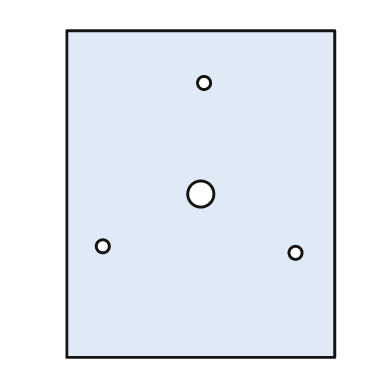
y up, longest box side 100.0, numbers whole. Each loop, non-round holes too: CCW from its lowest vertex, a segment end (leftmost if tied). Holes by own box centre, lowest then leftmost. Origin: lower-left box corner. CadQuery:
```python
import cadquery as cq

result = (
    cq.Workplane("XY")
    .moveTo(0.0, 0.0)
    .lineTo(82.0, 0.0)
    .lineTo(82.0, 100.0)
    .lineTo(0.0, 100.0)
    .close()
    .moveTo(70.0, 32.0)
    .circle(2.0)
    .moveTo(11.0, 34.0)
    .circle(2.0)
    .moveTo(41.0, 50.0)
    .circle(4.0)
    .moveTo(42.0, 84.0)
    .circle(2.0)
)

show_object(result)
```